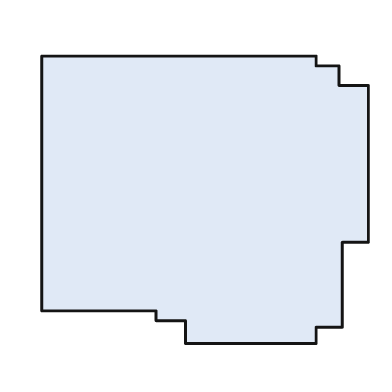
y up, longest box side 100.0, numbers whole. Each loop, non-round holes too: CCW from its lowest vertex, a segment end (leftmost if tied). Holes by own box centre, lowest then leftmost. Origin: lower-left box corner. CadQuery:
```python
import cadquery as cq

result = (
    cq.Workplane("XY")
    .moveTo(44.0, 0.0)
    .lineTo(84.0, 0.0)
    .lineTo(84.0, 5.0)
    .lineTo(92.0, 5.0)
    .lineTo(92.0, 31.0)
    .lineTo(100.0, 31.0)
    .lineTo(100.0, 79.0)
    .lineTo(91.0, 79.0)
    .lineTo(91.0, 85.0)
    .lineTo(84.0, 85.0)
    .lineTo(84.0, 88.0)
    .lineTo(0.0, 88.0)
    .lineTo(0.0, 10.0)
    .lineTo(35.0, 10.0)
    .lineTo(35.0, 7.0)
    .lineTo(44.0, 7.0)
    .close()
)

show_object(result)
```